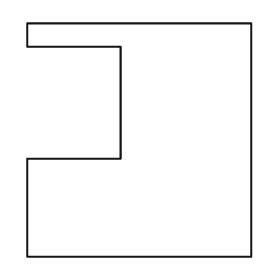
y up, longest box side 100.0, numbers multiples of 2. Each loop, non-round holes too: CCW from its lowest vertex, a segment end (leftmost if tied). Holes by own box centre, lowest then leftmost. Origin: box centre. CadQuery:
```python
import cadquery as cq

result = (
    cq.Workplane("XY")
    .moveTo(-48.0, -50.0)
    .lineTo(48.0, -50.0)
    .lineTo(48.0, 50.0)
    .lineTo(-48.0, 50.0)
    .lineTo(-48.0, 40.0)
    .lineTo(-8.0, 40.0)
    .lineTo(-8.0, -8.0)
    .lineTo(-48.0, -8.0)
    .close()
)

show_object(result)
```